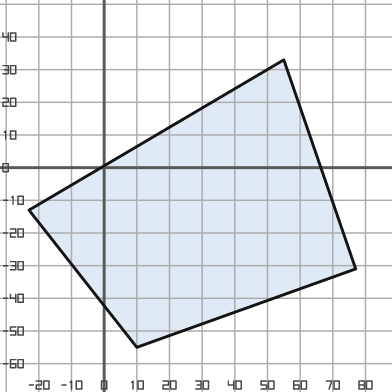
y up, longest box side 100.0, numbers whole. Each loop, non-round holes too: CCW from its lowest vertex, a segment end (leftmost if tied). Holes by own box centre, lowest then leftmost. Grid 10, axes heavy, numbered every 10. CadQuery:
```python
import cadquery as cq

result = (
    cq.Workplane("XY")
    .moveTo(10.0, -55.0)
    .lineTo(77.0, -31.0)
    .lineTo(55.0, 33.0)
    .lineTo(-23.0, -13.0)
    .close()
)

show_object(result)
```